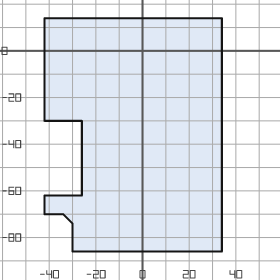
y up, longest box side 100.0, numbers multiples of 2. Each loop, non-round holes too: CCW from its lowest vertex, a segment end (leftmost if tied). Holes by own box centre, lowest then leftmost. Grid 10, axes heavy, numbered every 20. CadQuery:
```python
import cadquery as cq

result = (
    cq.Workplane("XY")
    .moveTo(-30.0, -86.0)
    .lineTo(34.0, -86.0)
    .lineTo(34.0, 14.0)
    .lineTo(-42.0, 14.0)
    .lineTo(-42.0, -30.0)
    .lineTo(-26.0, -30.0)
    .lineTo(-26.0, -62.0)
    .lineTo(-42.0, -62.0)
    .lineTo(-42.0, -70.0)
    .lineTo(-34.0, -70.0)
    .lineTo(-30.0, -74.0)
    .close()
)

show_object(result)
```